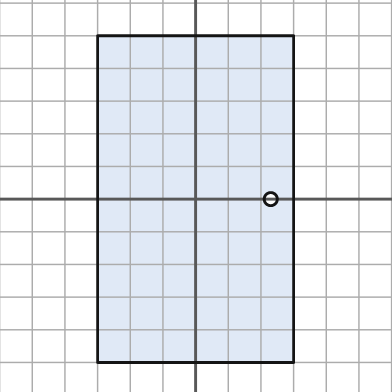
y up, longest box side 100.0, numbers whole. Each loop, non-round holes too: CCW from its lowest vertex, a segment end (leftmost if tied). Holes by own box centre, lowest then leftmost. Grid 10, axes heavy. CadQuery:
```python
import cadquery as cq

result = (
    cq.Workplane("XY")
    .moveTo(-30.0, -50.0)
    .lineTo(30.0, -50.0)
    .lineTo(30.0, 50.0)
    .lineTo(-30.0, 50.0)
    .close()
    .moveTo(23.0, 0.0)
    .circle(2.0)
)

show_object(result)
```